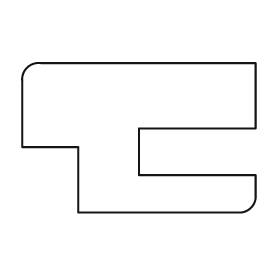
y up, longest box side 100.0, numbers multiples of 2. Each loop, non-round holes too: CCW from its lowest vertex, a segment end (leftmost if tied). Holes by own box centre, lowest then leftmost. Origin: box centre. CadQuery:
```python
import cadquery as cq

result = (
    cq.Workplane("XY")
    .moveTo(-26.0, -32.0)
    .lineTo(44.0, -32.0)
    .threePointArc((48.0, -30.0), (50.0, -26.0))
    .lineTo(50.0, -16.0)
    .lineTo(0.0, -16.0)
    .lineTo(0.0, 4.0)
    .lineTo(50.0, 4.0)
    .lineTo(50.0, 32.0)
    .lineTo(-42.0, 32.0)
    .threePointArc((-48.0, 30.0), (-50.0, 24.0))
    .lineTo(-50.0, -4.0)
    .lineTo(-26.0, -4.0)
    .close()
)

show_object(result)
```